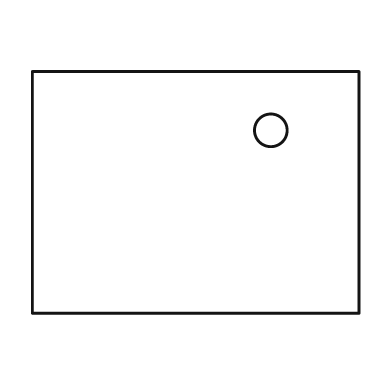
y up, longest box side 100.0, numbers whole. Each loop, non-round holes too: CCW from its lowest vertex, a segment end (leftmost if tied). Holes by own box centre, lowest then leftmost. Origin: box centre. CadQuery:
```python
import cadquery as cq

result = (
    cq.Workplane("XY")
    .moveTo(-50.0, -37.0)
    .lineTo(50.0, -37.0)
    .lineTo(50.0, 37.0)
    .lineTo(-50.0, 37.0)
    .close()
    .moveTo(23.0, 19.0)
    .circle(5.0)
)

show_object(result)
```